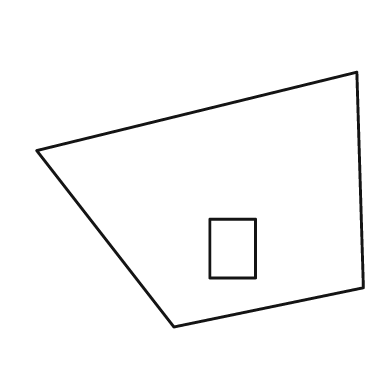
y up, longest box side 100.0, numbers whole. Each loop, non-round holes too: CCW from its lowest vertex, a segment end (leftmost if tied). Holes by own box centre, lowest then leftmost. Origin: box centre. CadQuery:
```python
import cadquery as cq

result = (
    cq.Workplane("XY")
    .moveTo(-8.0, -39.0)
    .lineTo(50.0, -27.0)
    .lineTo(48.0, 39.0)
    .lineTo(-50.0, 15.0)
    .close()
    .moveTo(3.0, -24.0)
    .lineTo(17.0, -24.0)
    .lineTo(17.0, -6.0)
    .lineTo(3.0, -6.0)
    .close()
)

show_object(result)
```